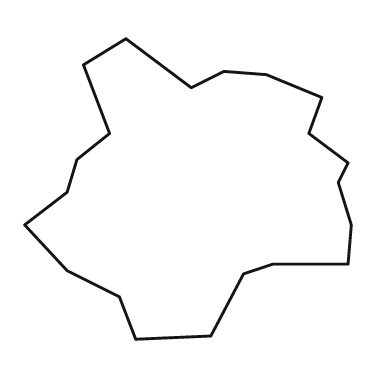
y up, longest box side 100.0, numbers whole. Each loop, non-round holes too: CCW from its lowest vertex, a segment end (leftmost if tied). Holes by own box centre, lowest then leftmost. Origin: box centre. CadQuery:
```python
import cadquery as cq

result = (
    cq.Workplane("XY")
    .moveTo(-16.0, -46.0)
    .lineTo(7.0, -45.0)
    .lineTo(17.0, -26.0)
    .lineTo(26.0, -23.0)
    .lineTo(49.0, -23.0)
    .lineTo(50.0, -11.0)
    .lineTo(46.0, 2.0)
    .lineTo(49.0, 8.0)
    .lineTo(37.0, 17.0)
    .lineTo(41.0, 28.0)
    .lineTo(24.0, 35.0)
    .lineTo(11.0, 36.0)
    .lineTo(1.0, 31.0)
    .lineTo(-19.0, 46.0)
    .lineTo(-32.0, 38.0)
    .lineTo(-24.0, 17.0)
    .lineTo(-34.0, 9.0)
    .lineTo(-37.0, -1.0)
    .lineTo(-50.0, -11.0)
    .lineTo(-37.0, -25.0)
    .lineTo(-21.0, -33.0)
    .close()
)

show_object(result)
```